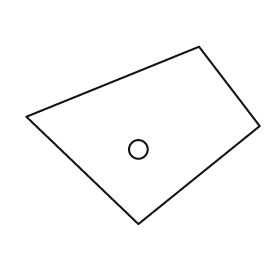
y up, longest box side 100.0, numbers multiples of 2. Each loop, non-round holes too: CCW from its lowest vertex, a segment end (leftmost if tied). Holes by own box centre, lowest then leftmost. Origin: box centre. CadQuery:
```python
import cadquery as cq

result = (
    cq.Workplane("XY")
    .moveTo(-2.0, -38.0)
    .lineTo(50.0, 4.0)
    .lineTo(24.0, 38.0)
    .lineTo(-50.0, 8.0)
    .close()
    .moveTo(-2.0, -6.0)
    .circle(4.0)
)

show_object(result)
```